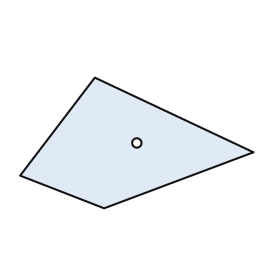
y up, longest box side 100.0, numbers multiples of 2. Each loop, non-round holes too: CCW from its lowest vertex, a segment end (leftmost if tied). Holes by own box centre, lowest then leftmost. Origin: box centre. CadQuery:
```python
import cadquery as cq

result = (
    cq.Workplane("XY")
    .moveTo(-14.0, -28.0)
    .lineTo(50.0, -4.0)
    .lineTo(-18.0, 28.0)
    .lineTo(-50.0, -14.0)
    .close()
    .moveTo(0.0, 0.0)
    .circle(2.0)
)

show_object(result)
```